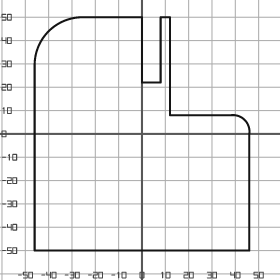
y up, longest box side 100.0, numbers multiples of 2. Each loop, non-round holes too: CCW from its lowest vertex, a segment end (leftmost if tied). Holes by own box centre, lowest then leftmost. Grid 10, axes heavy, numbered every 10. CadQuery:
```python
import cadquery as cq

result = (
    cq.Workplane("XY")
    .moveTo(-46.0, -50.0)
    .lineTo(46.0, -50.0)
    .lineTo(46.0, 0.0)
    .threePointArc((44.0, 6.0), (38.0, 8.0))
    .lineTo(12.0, 8.0)
    .lineTo(12.0, 50.0)
    .lineTo(8.0, 50.0)
    .lineTo(8.0, 22.0)
    .lineTo(0.0, 22.0)
    .lineTo(0.0, 50.0)
    .lineTo(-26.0, 50.0)
    .threePointArc((-40.0, 44.0), (-46.0, 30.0))
    .close()
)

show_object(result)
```